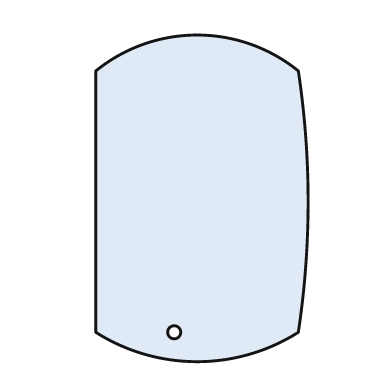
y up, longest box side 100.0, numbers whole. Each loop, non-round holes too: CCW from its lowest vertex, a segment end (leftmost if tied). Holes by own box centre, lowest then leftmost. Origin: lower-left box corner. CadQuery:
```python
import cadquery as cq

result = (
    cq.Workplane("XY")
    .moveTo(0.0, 9.0)
    .threePointArc((31.0, 0.0), (62.0, 9.0))
    .threePointArc((65.0, 49.0), (62.0, 89.0))
    .threePointArc((31.0, 100.0), (0.0, 89.0))
    .close()
    .moveTo(24.0, 9.0)
    .circle(2.0)
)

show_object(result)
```